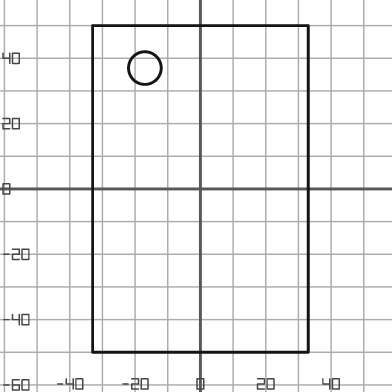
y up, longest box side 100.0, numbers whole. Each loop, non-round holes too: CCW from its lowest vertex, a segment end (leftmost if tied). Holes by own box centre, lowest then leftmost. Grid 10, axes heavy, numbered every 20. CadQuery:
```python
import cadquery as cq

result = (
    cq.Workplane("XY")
    .moveTo(-33.0, -50.0)
    .lineTo(33.0, -50.0)
    .lineTo(33.0, 50.0)
    .lineTo(-33.0, 50.0)
    .close()
    .moveTo(-17.0, 37.0)
    .circle(5.0)
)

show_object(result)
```